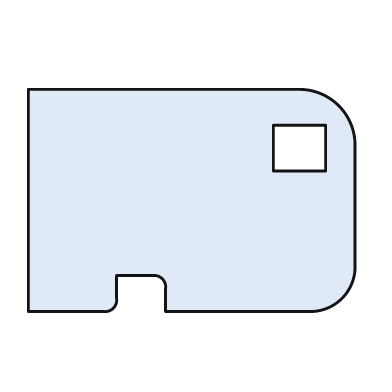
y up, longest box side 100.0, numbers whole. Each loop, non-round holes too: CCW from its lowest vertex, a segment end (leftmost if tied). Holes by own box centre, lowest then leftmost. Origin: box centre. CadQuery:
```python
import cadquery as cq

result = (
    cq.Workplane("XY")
    .moveTo(-50.0, -34.0)
    .lineTo(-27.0, -34.0)
    .threePointArc((-24.0, -33.0), (-23.0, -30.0))
    .lineTo(-23.0, -23.0)
    .lineTo(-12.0, -23.0)
    .threePointArc((-9.0, -24.0), (-8.0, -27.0))
    .lineTo(-8.0, -34.0)
    .lineTo(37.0, -34.0)
    .threePointArc((46.0, -30.0), (50.0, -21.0))
    .lineTo(50.0, 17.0)
    .threePointArc((45.0, 29.0), (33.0, 34.0))
    .lineTo(-50.0, 34.0)
    .close()
    .moveTo(25.0, 9.0)
    .lineTo(41.0, 9.0)
    .lineTo(41.0, 23.0)
    .lineTo(25.0, 23.0)
    .close()
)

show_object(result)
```